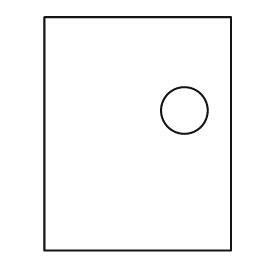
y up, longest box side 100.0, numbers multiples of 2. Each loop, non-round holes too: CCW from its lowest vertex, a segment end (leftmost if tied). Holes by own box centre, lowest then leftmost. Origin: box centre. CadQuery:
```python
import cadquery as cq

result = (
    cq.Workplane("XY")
    .moveTo(-40.0, -50.0)
    .lineTo(40.0, -50.0)
    .lineTo(40.0, 50.0)
    .lineTo(-40.0, 50.0)
    .close()
    .moveTo(20.0, 10.0)
    .circle(10.0)
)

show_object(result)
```